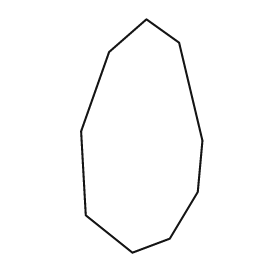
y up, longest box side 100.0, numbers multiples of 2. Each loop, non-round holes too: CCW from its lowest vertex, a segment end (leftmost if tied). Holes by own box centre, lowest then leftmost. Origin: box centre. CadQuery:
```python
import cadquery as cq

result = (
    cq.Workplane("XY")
    .moveTo(-4.0, -50.0)
    .lineTo(12.0, -44.0)
    .lineTo(24.0, -24.0)
    .lineTo(26.0, -2.0)
    .lineTo(16.0, 40.0)
    .lineTo(2.0, 50.0)
    .lineTo(-14.0, 36.0)
    .lineTo(-26.0, 2.0)
    .lineTo(-24.0, -34.0)
    .close()
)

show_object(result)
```